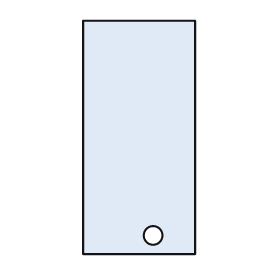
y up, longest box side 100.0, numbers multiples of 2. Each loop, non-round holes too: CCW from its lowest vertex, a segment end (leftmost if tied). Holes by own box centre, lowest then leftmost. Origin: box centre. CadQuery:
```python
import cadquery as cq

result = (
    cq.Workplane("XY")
    .moveTo(-24.0, -50.0)
    .lineTo(24.0, -50.0)
    .lineTo(24.0, 50.0)
    .lineTo(-24.0, 50.0)
    .close()
    .moveTo(6.0, -42.0)
    .circle(4.0)
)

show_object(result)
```